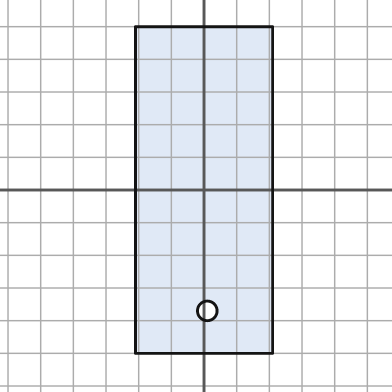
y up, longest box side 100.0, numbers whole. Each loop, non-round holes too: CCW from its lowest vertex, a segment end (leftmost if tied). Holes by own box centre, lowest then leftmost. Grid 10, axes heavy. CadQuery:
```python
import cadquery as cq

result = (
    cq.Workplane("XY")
    .moveTo(-21.0, -50.0)
    .lineTo(21.0, -50.0)
    .lineTo(21.0, 50.0)
    .lineTo(-21.0, 50.0)
    .close()
    .moveTo(1.0, -37.0)
    .circle(3.0)
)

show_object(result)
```